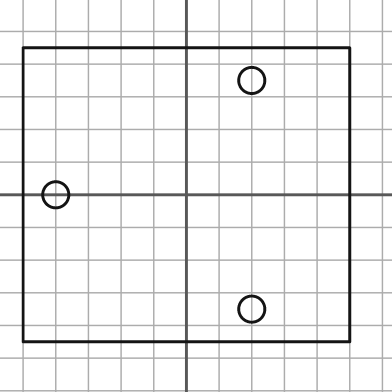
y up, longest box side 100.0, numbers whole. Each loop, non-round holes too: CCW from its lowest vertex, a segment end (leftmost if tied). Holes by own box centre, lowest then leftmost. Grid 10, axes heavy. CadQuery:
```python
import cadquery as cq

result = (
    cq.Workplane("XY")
    .moveTo(-50.0, -45.0)
    .lineTo(50.0, -45.0)
    .lineTo(50.0, 45.0)
    .lineTo(-50.0, 45.0)
    .close()
    .moveTo(20.0, -35.0)
    .circle(4.0)
    .moveTo(-40.0, 0.0)
    .circle(4.0)
    .moveTo(20.0, 35.0)
    .circle(4.0)
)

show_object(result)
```